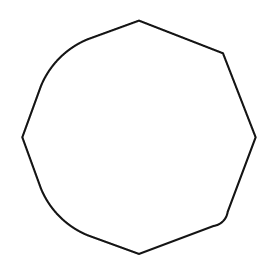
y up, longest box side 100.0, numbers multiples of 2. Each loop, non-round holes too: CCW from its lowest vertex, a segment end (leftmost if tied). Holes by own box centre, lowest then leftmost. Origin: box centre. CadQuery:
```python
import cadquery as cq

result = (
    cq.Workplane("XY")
    .moveTo(0.0, -50.0)
    .lineTo(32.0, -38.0)
    .threePointArc((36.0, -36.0), (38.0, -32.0))
    .lineTo(50.0, 0.0)
    .lineTo(36.0, 36.0)
    .lineTo(0.0, 50.0)
    .lineTo(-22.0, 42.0)
    .threePointArc((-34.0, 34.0), (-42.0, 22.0))
    .lineTo(-50.0, 0.0)
    .lineTo(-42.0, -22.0)
    .threePointArc((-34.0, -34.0), (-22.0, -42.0))
    .close()
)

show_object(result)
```